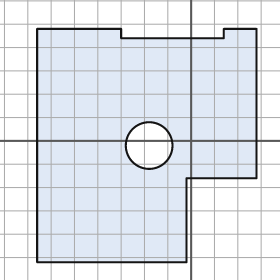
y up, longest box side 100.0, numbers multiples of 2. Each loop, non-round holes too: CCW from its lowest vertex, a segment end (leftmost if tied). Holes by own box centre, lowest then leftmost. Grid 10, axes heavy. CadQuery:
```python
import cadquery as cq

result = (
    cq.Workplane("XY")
    .moveTo(-66.0, -52.0)
    .lineTo(-2.0, -52.0)
    .lineTo(-2.0, -16.0)
    .lineTo(28.0, -16.0)
    .lineTo(28.0, 48.0)
    .lineTo(14.0, 48.0)
    .lineTo(14.0, 44.0)
    .lineTo(-30.0, 44.0)
    .lineTo(-30.0, 48.0)
    .lineTo(-66.0, 48.0)
    .close()
    .moveTo(-18.0, -2.0)
    .circle(10.0)
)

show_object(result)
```